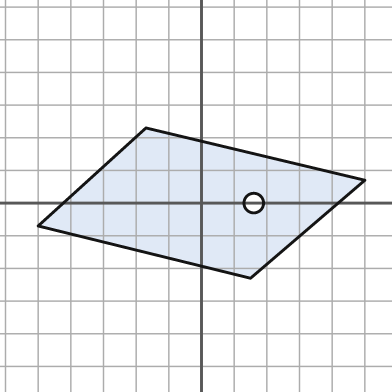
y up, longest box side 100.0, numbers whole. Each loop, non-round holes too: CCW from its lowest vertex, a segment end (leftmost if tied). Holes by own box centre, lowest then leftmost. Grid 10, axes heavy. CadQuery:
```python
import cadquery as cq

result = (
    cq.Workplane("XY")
    .moveTo(15.0, -23.0)
    .lineTo(50.0, 7.0)
    .lineTo(-17.0, 23.0)
    .lineTo(-50.0, -7.0)
    .close()
    .moveTo(16.0, 0.0)
    .circle(3.0)
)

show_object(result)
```